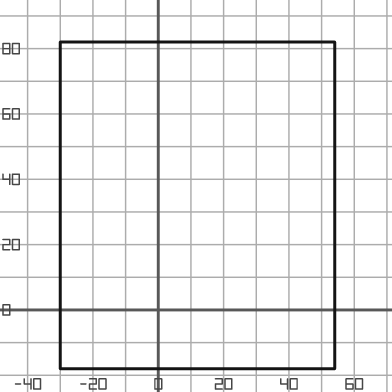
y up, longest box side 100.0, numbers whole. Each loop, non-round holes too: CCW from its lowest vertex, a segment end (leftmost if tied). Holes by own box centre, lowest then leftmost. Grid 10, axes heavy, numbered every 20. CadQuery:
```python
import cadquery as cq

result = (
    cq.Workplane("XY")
    .moveTo(-30.0, -18.0)
    .lineTo(54.0, -18.0)
    .lineTo(54.0, 82.0)
    .lineTo(-30.0, 82.0)
    .close()
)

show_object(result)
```